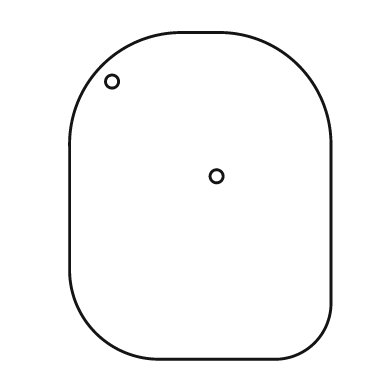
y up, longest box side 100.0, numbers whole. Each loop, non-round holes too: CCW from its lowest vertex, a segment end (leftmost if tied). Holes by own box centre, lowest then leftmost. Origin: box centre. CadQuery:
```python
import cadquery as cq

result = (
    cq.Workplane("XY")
    .moveTo(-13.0, -50.0)
    .lineTo(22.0, -50.0)
    .threePointArc((35.0, -45.0), (40.0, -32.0))
    .lineTo(40.0, 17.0)
    .threePointArc((30.0, 40.0), (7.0, 50.0))
    .lineTo(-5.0, 50.0)
    .threePointArc((-30.0, 40.0), (-40.0, 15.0))
    .lineTo(-40.0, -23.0)
    .threePointArc((-32.0, -42.0), (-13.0, -50.0))
    .close()
    .moveTo(5.0, 6.0)
    .circle(2.0)
    .moveTo(-27.0, 35.0)
    .circle(2.0)
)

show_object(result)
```